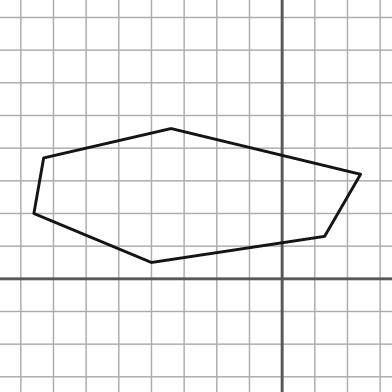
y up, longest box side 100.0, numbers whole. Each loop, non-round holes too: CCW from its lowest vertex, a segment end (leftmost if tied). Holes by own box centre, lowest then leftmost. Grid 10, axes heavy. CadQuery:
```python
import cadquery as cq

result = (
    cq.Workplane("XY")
    .moveTo(-40.0, 5.0)
    .lineTo(13.0, 13.0)
    .lineTo(24.0, 32.0)
    .lineTo(-34.0, 46.0)
    .lineTo(-73.0, 37.0)
    .lineTo(-76.0, 20.0)
    .close()
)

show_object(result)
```